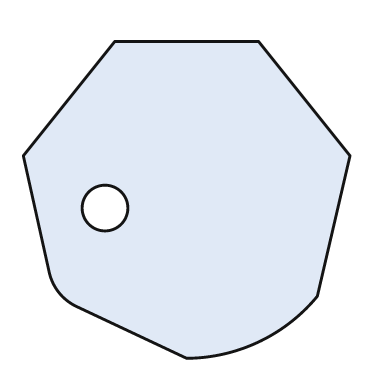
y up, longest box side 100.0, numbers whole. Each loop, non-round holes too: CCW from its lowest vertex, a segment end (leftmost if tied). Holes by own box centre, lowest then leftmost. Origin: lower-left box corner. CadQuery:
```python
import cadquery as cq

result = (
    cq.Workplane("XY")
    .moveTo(50.0, 0.0)
    .threePointArc((72.0, 5.0), (90.0, 19.0))
    .lineTo(100.0, 62.0)
    .lineTo(72.0, 97.0)
    .lineTo(28.0, 97.0)
    .lineTo(0.0, 62.0)
    .lineTo(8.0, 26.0)
    .threePointArc((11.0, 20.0), (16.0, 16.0))
    .close()
    .moveTo(25.0, 46.0)
    .circle(7.0)
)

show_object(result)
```